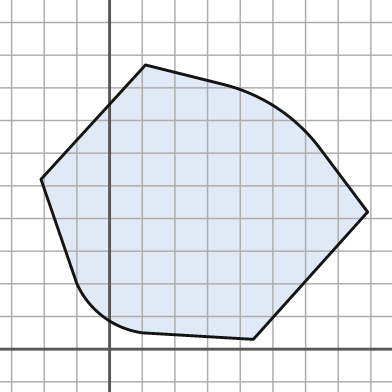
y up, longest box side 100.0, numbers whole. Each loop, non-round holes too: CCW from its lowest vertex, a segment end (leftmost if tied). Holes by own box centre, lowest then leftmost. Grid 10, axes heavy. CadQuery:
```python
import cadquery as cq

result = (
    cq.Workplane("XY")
    .moveTo(44.0, 3.0)
    .lineTo(79.0, 42.0)
    .lineTo(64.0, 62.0)
    .threePointArc((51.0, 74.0), (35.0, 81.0))
    .lineTo(11.0, 87.0)
    .lineTo(-21.0, 52.0)
    .lineTo(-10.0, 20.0)
    .threePointArc((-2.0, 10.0), (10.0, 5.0))
    .close()
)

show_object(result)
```